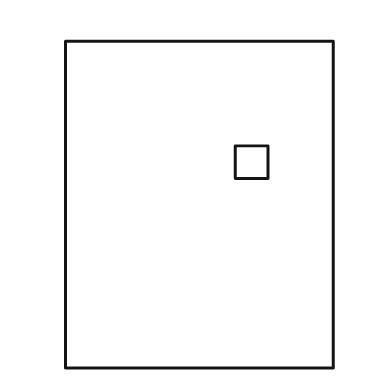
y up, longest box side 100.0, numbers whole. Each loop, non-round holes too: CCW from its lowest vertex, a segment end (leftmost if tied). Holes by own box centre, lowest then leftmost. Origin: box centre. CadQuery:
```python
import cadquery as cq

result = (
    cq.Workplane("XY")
    .moveTo(-41.0, -50.0)
    .lineTo(41.0, -50.0)
    .lineTo(41.0, 50.0)
    .lineTo(-41.0, 50.0)
    .close()
    .moveTo(11.0, 8.0)
    .lineTo(21.0, 8.0)
    .lineTo(21.0, 18.0)
    .lineTo(11.0, 18.0)
    .close()
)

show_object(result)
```